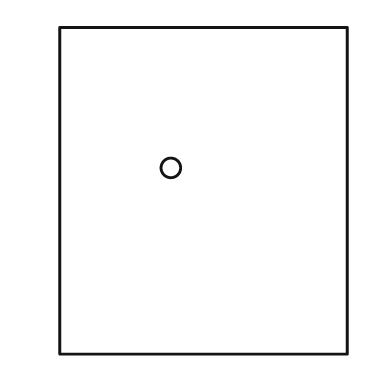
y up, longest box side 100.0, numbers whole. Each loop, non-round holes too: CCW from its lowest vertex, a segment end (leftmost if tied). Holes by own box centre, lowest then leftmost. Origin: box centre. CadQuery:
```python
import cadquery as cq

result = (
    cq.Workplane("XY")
    .moveTo(-44.0, -50.0)
    .lineTo(44.0, -50.0)
    .lineTo(44.0, 50.0)
    .lineTo(-44.0, 50.0)
    .close()
    .moveTo(-10.0, 7.0)
    .circle(3.0)
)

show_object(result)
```